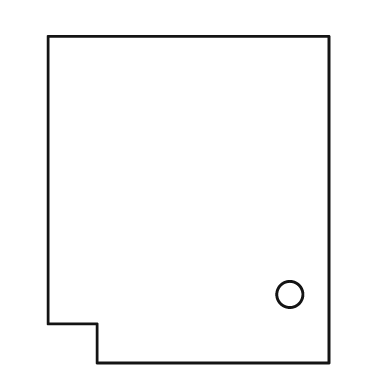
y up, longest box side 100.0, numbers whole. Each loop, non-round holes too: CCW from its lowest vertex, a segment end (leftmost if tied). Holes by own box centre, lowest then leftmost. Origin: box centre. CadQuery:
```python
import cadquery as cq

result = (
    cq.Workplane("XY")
    .moveTo(-28.0, -50.0)
    .lineTo(43.0, -50.0)
    .lineTo(43.0, 50.0)
    .lineTo(-43.0, 50.0)
    .lineTo(-43.0, -38.0)
    .lineTo(-28.0, -38.0)
    .close()
    .moveTo(31.0, -29.0)
    .circle(4.0)
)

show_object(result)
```